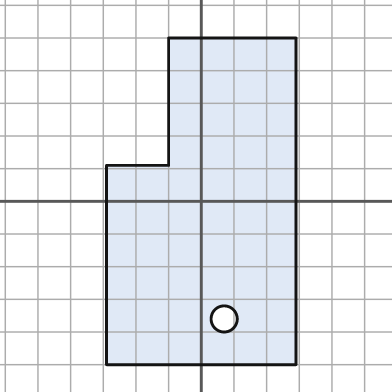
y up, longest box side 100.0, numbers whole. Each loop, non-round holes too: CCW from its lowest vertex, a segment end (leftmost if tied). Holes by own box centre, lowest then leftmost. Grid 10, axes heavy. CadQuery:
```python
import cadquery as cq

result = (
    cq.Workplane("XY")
    .moveTo(-29.0, -50.0)
    .lineTo(29.0, -50.0)
    .lineTo(29.0, 50.0)
    .lineTo(-10.0, 50.0)
    .lineTo(-10.0, 11.0)
    .lineTo(-29.0, 11.0)
    .close()
    .moveTo(7.0, -36.0)
    .circle(4.0)
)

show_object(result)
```